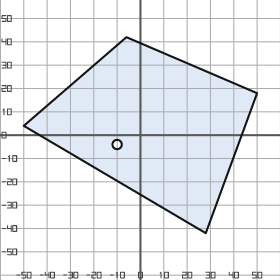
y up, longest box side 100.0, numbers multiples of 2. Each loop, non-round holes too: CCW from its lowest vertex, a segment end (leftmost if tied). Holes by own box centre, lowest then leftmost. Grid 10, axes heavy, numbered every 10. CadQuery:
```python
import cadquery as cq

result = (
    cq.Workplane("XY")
    .moveTo(28.0, -42.0)
    .lineTo(50.0, 18.0)
    .lineTo(-6.0, 42.0)
    .lineTo(-50.0, 4.0)
    .close()
    .moveTo(-10.0, -4.0)
    .circle(2.0)
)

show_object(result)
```